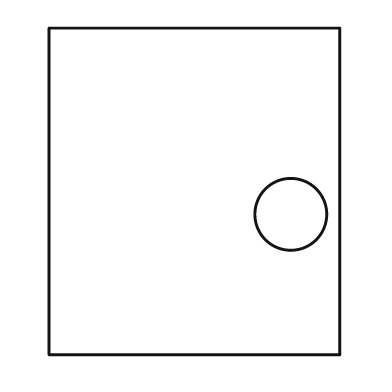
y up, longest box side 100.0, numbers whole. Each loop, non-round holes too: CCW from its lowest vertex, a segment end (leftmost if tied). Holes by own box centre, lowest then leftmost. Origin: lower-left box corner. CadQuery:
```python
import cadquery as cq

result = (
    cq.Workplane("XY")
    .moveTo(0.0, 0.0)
    .lineTo(89.0, 0.0)
    .lineTo(89.0, 100.0)
    .lineTo(0.0, 100.0)
    .close()
    .moveTo(74.0, 43.0)
    .circle(11.0)
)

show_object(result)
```